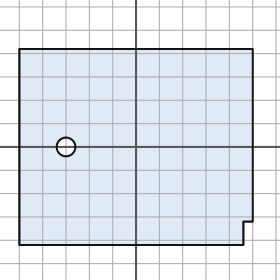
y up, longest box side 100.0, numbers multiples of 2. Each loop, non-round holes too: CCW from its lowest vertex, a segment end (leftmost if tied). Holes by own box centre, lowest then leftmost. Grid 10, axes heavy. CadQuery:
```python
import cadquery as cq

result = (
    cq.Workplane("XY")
    .moveTo(-50.0, -42.0)
    .lineTo(46.0, -42.0)
    .lineTo(46.0, -32.0)
    .lineTo(50.0, -32.0)
    .lineTo(50.0, 42.0)
    .lineTo(-50.0, 42.0)
    .close()
    .moveTo(-30.0, 0.0)
    .circle(4.0)
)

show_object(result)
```